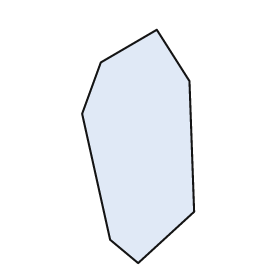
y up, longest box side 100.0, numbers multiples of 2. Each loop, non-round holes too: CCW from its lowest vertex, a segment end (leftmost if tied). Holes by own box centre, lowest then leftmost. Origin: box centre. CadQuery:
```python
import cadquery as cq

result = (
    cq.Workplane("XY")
    .moveTo(0.0, -50.0)
    .lineTo(24.0, -28.0)
    .lineTo(22.0, 28.0)
    .lineTo(8.0, 50.0)
    .lineTo(-16.0, 36.0)
    .lineTo(-24.0, 14.0)
    .lineTo(-12.0, -40.0)
    .close()
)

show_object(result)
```